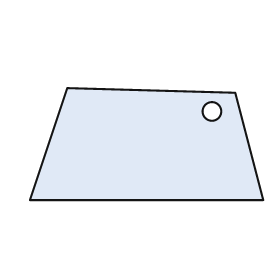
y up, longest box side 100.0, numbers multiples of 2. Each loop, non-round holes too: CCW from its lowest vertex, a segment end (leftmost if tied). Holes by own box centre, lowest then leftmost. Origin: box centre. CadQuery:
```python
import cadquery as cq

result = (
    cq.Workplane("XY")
    .moveTo(-50.0, -24.0)
    .lineTo(50.0, -24.0)
    .lineTo(38.0, 22.0)
    .lineTo(-34.0, 24.0)
    .close()
    .moveTo(28.0, 14.0)
    .circle(4.0)
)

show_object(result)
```